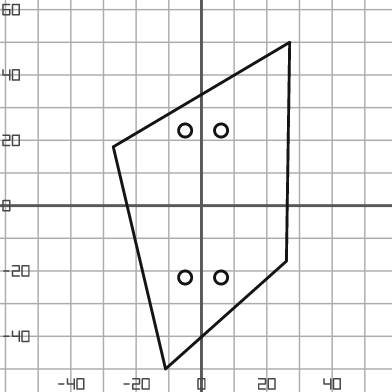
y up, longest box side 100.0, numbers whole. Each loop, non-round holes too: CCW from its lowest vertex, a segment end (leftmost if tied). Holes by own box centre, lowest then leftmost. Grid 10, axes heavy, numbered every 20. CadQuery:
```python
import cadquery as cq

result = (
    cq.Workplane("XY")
    .moveTo(-11.0, -50.0)
    .lineTo(26.0, -17.0)
    .lineTo(27.0, 50.0)
    .lineTo(-27.0, 18.0)
    .close()
    .moveTo(-5.0, -22.0)
    .circle(2.0)
    .moveTo(6.0, -22.0)
    .circle(2.0)
    .moveTo(-5.0, 23.0)
    .circle(2.0)
    .moveTo(6.0, 23.0)
    .circle(2.0)
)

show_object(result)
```